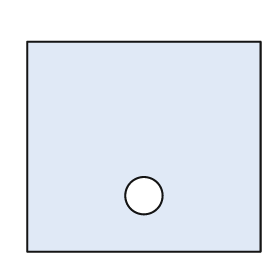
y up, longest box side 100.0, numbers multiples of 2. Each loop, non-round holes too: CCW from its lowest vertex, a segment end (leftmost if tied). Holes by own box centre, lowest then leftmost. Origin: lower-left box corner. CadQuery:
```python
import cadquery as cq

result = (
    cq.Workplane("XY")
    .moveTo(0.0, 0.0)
    .lineTo(100.0, 0.0)
    .lineTo(100.0, 90.0)
    .lineTo(0.0, 90.0)
    .close()
    .moveTo(50.0, 24.0)
    .circle(8.0)
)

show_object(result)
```